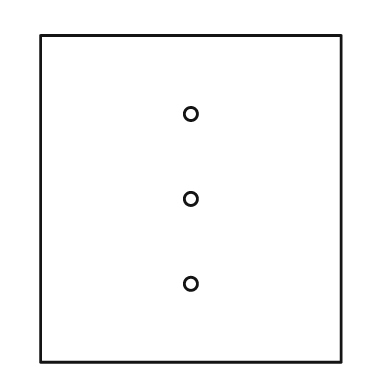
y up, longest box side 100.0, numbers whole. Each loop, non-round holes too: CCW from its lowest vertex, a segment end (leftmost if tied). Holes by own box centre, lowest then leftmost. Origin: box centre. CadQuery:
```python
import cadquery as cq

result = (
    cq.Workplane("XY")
    .moveTo(-46.0, -50.0)
    .lineTo(46.0, -50.0)
    .lineTo(46.0, 50.0)
    .lineTo(-46.0, 50.0)
    .close()
    .moveTo(0.0, -26.0)
    .circle(2.0)
    .moveTo(0.0, 0.0)
    .circle(2.0)
    .moveTo(0.0, 26.0)
    .circle(2.0)
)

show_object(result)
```